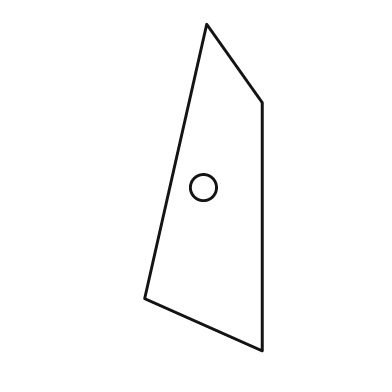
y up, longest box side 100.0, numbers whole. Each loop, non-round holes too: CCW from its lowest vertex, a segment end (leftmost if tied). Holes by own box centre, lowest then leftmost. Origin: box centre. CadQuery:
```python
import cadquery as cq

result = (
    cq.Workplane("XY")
    .moveTo(18.0, -50.0)
    .lineTo(18.0, 26.0)
    .lineTo(1.0, 50.0)
    .lineTo(-18.0, -34.0)
    .close()
    .moveTo(0.0, 0.0)
    .circle(4.0)
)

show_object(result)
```